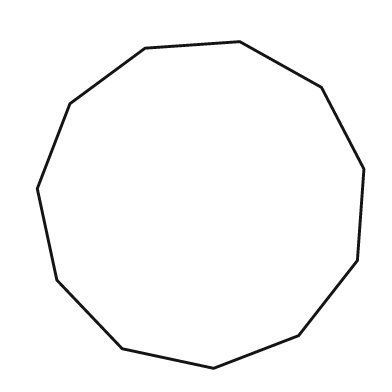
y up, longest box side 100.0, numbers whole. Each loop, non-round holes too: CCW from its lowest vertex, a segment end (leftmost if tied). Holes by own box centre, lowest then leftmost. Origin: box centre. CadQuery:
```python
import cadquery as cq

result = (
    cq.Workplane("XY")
    .moveTo(4.0, -50.0)
    .lineTo(30.0, -40.0)
    .lineTo(48.0, -17.0)
    .lineTo(50.0, 11.0)
    .lineTo(37.0, 36.0)
    .lineTo(12.0, 50.0)
    .lineTo(-17.0, 48.0)
    .lineTo(-40.0, 31.0)
    .lineTo(-50.0, 5.0)
    .lineTo(-44.0, -23.0)
    .lineTo(-24.0, -44.0)
    .close()
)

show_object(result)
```